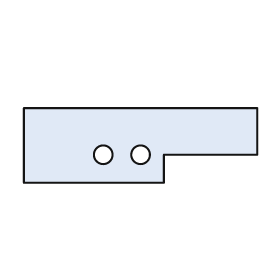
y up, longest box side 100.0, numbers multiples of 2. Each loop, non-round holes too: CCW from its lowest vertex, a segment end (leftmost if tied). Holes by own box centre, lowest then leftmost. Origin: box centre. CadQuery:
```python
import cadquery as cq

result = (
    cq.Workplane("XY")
    .moveTo(-50.0, -16.0)
    .lineTo(10.0, -16.0)
    .lineTo(10.0, -4.0)
    .lineTo(50.0, -4.0)
    .lineTo(50.0, 16.0)
    .lineTo(-50.0, 16.0)
    .close()
    .moveTo(-16.0, -4.0)
    .circle(4.0)
    .moveTo(0.0, -4.0)
    .circle(4.0)
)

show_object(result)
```